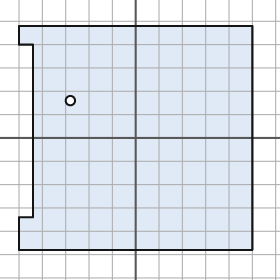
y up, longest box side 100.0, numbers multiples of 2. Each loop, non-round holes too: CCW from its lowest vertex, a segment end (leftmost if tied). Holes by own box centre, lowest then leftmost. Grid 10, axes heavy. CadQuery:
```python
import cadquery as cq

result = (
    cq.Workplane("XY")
    .moveTo(-50.0, -48.0)
    .lineTo(50.0, -48.0)
    .lineTo(50.0, 48.0)
    .lineTo(-50.0, 48.0)
    .lineTo(-50.0, 40.0)
    .lineTo(-44.0, 40.0)
    .lineTo(-44.0, -34.0)
    .lineTo(-50.0, -34.0)
    .close()
    .moveTo(-28.0, 16.0)
    .circle(2.0)
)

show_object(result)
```